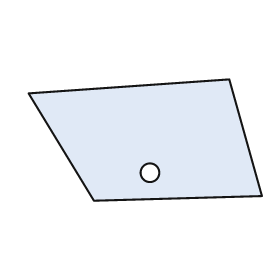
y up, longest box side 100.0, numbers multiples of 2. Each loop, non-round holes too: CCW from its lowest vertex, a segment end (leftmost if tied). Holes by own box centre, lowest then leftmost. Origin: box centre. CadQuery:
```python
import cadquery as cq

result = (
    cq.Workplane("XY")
    .moveTo(-22.0, -26.0)
    .lineTo(50.0, -24.0)
    .lineTo(36.0, 26.0)
    .lineTo(-50.0, 20.0)
    .close()
    .moveTo(2.0, -14.0)
    .circle(4.0)
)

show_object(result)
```